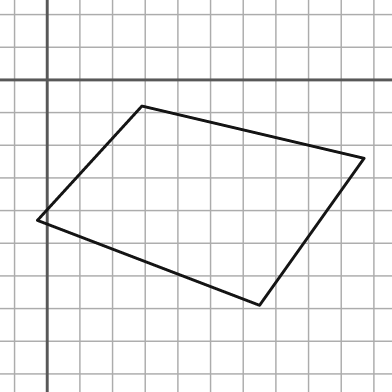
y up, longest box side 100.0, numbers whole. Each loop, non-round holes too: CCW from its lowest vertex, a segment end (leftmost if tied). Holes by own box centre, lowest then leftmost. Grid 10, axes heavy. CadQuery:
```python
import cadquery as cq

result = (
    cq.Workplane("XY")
    .moveTo(65.0, -69.0)
    .lineTo(97.0, -24.0)
    .lineTo(29.0, -8.0)
    .lineTo(-3.0, -43.0)
    .close()
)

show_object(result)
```